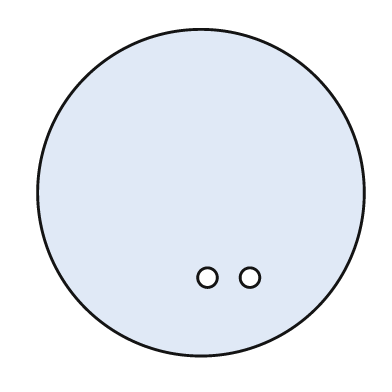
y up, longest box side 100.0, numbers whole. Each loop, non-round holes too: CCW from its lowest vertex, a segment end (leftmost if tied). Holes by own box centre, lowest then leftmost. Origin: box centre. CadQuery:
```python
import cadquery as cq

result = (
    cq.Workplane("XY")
    .moveTo(0.0, 0.0)
    .circle(50.0)
    .moveTo(2.0, -26.0)
    .circle(3.0)
    .moveTo(15.0, -26.0)
    .circle(3.0)
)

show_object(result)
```